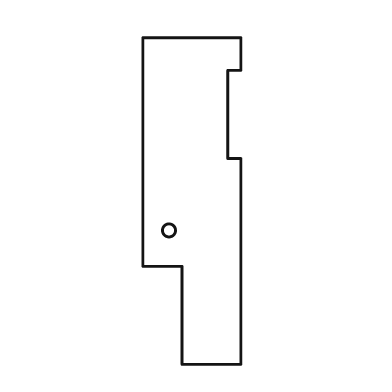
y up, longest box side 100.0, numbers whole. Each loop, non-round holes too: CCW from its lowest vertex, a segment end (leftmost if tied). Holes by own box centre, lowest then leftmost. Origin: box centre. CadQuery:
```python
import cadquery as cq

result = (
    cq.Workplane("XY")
    .moveTo(-3.0, -50.0)
    .lineTo(15.0, -50.0)
    .lineTo(15.0, 13.0)
    .lineTo(11.0, 13.0)
    .lineTo(11.0, 40.0)
    .lineTo(15.0, 40.0)
    .lineTo(15.0, 50.0)
    .lineTo(-15.0, 50.0)
    .lineTo(-15.0, -20.0)
    .lineTo(-3.0, -20.0)
    .close()
    .moveTo(-7.0, -9.0)
    .circle(2.0)
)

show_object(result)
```